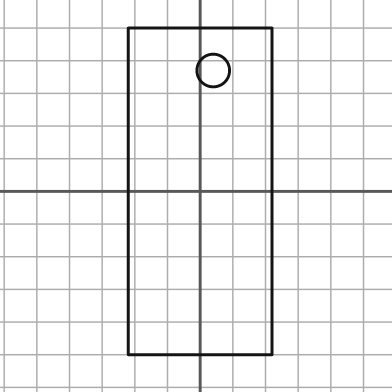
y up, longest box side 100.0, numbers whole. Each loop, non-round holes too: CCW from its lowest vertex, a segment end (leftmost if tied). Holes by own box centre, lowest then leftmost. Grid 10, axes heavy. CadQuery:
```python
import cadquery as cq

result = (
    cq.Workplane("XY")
    .moveTo(-22.0, -50.0)
    .lineTo(22.0, -50.0)
    .lineTo(22.0, 50.0)
    .lineTo(-22.0, 50.0)
    .close()
    .moveTo(4.0, 37.0)
    .circle(5.0)
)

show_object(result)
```